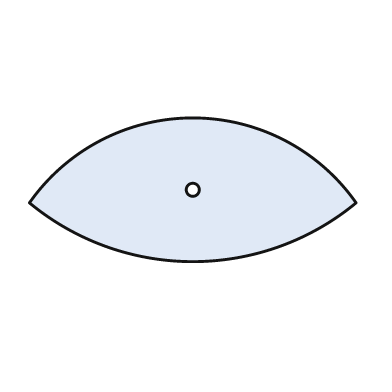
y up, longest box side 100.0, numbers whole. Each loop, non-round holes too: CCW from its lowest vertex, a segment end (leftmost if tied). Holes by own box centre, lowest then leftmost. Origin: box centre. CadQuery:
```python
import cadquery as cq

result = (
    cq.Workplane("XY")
    .moveTo(-50.0, -4.0)
    .threePointArc((0.0, -22.0), (50.0, -4.0))
    .threePointArc((0.0, 22.0), (-50.0, -4.0))
    .close()
    .moveTo(0.0, 0.0)
    .circle(2.0)
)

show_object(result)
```